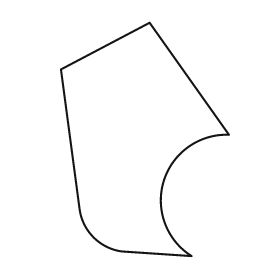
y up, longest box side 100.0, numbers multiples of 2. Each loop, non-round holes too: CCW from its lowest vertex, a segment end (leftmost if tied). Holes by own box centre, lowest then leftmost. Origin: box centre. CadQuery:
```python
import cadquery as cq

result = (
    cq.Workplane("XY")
    .moveTo(20.0, -50.0)
    .threePointArc((8.0, -18.0), (36.0, 2.0))
    .lineTo(2.0, 50.0)
    .lineTo(-36.0, 30.0)
    .lineTo(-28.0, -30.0)
    .threePointArc((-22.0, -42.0), (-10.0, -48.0))
    .close()
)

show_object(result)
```